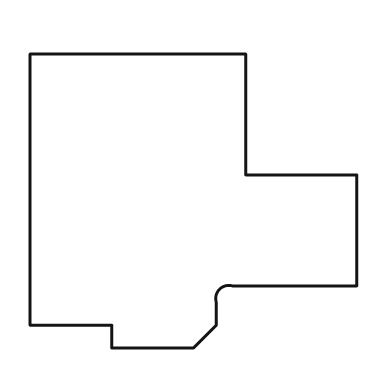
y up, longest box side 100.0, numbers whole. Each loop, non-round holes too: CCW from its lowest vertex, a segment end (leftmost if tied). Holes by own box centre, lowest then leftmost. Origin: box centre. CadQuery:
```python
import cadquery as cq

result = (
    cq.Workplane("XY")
    .moveTo(-25.0, -45.0)
    .lineTo(0.0, -45.0)
    .lineTo(7.0, -38.0)
    .lineTo(7.0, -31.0)
    .threePointArc((8.0, -27.0), (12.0, -26.0))
    .lineTo(50.0, -26.0)
    .lineTo(50.0, 8.0)
    .lineTo(16.0, 8.0)
    .lineTo(16.0, 45.0)
    .lineTo(-50.0, 45.0)
    .lineTo(-50.0, -38.0)
    .lineTo(-25.0, -38.0)
    .close()
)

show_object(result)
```